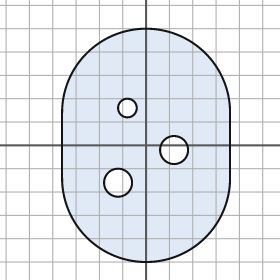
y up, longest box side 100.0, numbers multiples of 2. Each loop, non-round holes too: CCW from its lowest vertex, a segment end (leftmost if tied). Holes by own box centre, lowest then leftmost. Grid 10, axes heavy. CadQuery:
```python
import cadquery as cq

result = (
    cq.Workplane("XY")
    .moveTo(-36.0, -14.0)
    .threePointArc((0.0, -50.0), (36.0, -14.0))
    .lineTo(36.0, 14.0)
    .threePointArc((0.0, 50.0), (-36.0, 14.0))
    .close()
    .moveTo(-12.0, -16.0)
    .circle(6.0)
    .moveTo(12.0, -2.0)
    .circle(6.0)
    .moveTo(-8.0, 16.0)
    .circle(4.0)
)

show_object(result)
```